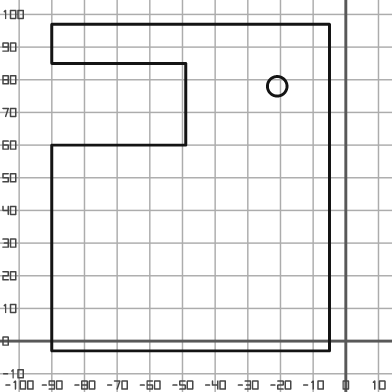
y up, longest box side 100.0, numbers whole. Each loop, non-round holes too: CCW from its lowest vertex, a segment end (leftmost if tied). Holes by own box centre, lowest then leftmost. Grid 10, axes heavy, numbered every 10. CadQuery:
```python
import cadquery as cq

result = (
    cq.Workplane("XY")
    .moveTo(-90.0, -3.0)
    .lineTo(-5.0, -3.0)
    .lineTo(-5.0, 97.0)
    .lineTo(-90.0, 97.0)
    .lineTo(-90.0, 85.0)
    .lineTo(-49.0, 85.0)
    .lineTo(-49.0, 60.0)
    .lineTo(-90.0, 60.0)
    .close()
    .moveTo(-21.0, 78.0)
    .circle(3.0)
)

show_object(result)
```